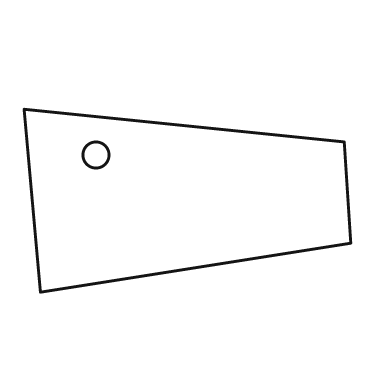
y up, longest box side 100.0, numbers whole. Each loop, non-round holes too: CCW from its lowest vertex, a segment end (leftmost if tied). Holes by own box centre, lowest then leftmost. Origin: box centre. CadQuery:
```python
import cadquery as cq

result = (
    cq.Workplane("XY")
    .moveTo(-45.0, -28.0)
    .lineTo(50.0, -13.0)
    .lineTo(48.0, 18.0)
    .lineTo(-50.0, 28.0)
    .close()
    .moveTo(-28.0, 14.0)
    .circle(4.0)
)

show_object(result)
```